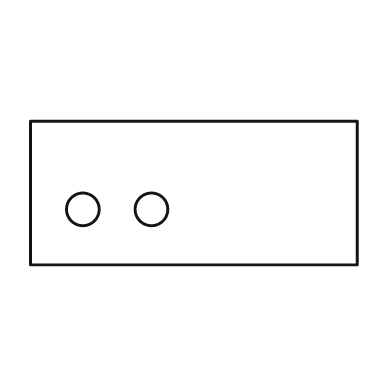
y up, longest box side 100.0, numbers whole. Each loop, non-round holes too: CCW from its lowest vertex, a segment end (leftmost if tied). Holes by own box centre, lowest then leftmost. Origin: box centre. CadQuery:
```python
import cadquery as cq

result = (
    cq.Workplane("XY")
    .moveTo(-50.0, -22.0)
    .lineTo(50.0, -22.0)
    .lineTo(50.0, 22.0)
    .lineTo(-50.0, 22.0)
    .close()
    .moveTo(-34.0, -5.0)
    .circle(5.0)
    .moveTo(-13.0, -5.0)
    .circle(5.0)
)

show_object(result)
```